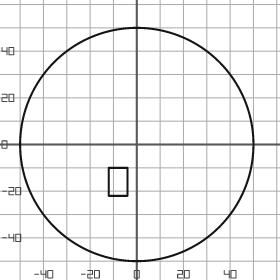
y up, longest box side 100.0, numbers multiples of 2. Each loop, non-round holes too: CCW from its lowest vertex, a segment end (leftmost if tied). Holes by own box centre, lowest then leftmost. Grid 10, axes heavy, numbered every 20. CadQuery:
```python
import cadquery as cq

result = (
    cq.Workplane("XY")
    .moveTo(0.0, 0.0)
    .circle(50.0)
    .moveTo(-12.0, -22.0)
    .lineTo(-4.0, -22.0)
    .lineTo(-4.0, -10.0)
    .lineTo(-12.0, -10.0)
    .close()
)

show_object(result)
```